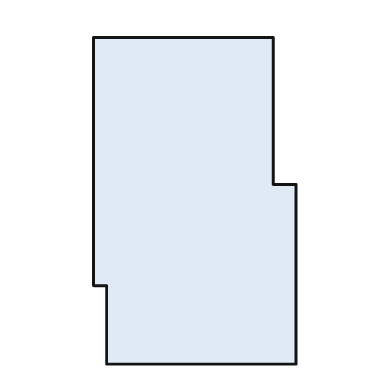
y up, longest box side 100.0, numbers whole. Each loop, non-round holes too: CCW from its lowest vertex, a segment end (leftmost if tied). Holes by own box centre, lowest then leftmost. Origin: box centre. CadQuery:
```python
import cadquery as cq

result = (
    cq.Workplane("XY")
    .moveTo(-27.0, -50.0)
    .lineTo(31.0, -50.0)
    .lineTo(31.0, 5.0)
    .lineTo(24.0, 5.0)
    .lineTo(24.0, 50.0)
    .lineTo(-31.0, 50.0)
    .lineTo(-31.0, -26.0)
    .lineTo(-27.0, -26.0)
    .close()
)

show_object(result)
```